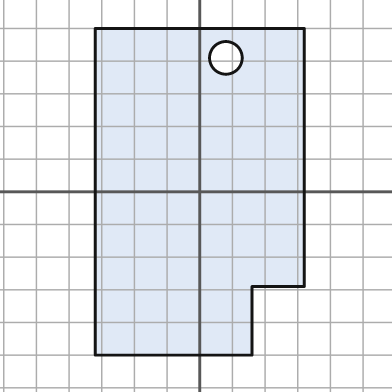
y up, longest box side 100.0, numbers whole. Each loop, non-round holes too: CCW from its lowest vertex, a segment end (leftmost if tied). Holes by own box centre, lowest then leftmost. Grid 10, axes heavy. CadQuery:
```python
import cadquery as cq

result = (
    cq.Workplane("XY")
    .moveTo(-32.0, -50.0)
    .lineTo(16.0, -50.0)
    .lineTo(16.0, -29.0)
    .lineTo(32.0, -29.0)
    .lineTo(32.0, 50.0)
    .lineTo(-32.0, 50.0)
    .close()
    .moveTo(8.0, 41.0)
    .circle(5.0)
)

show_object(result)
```